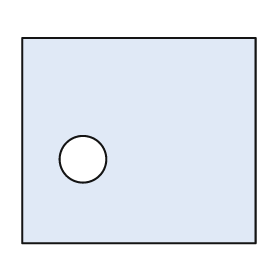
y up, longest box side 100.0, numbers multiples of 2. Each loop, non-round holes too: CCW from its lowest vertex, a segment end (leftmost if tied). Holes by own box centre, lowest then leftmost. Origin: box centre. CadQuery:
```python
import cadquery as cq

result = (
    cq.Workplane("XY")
    .moveTo(-50.0, -44.0)
    .lineTo(50.0, -44.0)
    .lineTo(50.0, 44.0)
    .lineTo(-50.0, 44.0)
    .close()
    .moveTo(-24.0, -8.0)
    .circle(10.0)
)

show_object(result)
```